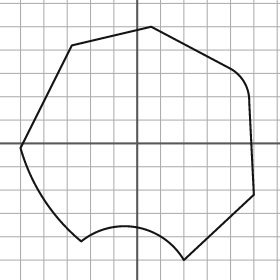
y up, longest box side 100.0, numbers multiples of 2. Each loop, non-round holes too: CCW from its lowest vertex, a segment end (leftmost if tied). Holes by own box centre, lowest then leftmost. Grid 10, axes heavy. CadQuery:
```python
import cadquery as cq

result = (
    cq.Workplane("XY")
    .moveTo(20.0, -50.0)
    .lineTo(50.0, -22.0)
    .lineTo(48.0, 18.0)
    .threePointArc((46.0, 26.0), (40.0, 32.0))
    .lineTo(6.0, 50.0)
    .lineTo(-28.0, 42.0)
    .lineTo(-50.0, -2.0)
    .threePointArc((-40.0, -24.0), (-24.0, -42.0))
    .threePointArc((0.0, -36.0), (20.0, -50.0))
    .close()
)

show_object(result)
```